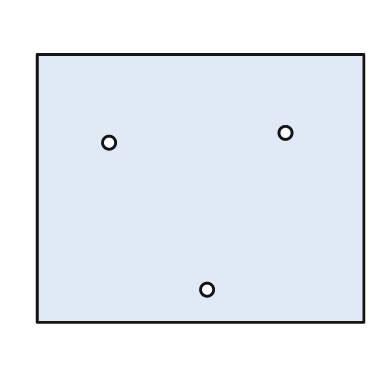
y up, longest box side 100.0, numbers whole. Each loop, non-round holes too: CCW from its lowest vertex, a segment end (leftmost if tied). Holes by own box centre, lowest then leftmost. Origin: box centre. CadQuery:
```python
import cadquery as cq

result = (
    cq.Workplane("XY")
    .moveTo(-50.0, -41.0)
    .lineTo(50.0, -41.0)
    .lineTo(50.0, 41.0)
    .lineTo(-50.0, 41.0)
    .close()
    .moveTo(2.0, -31.0)
    .circle(2.0)
    .moveTo(-28.0, 14.0)
    .circle(2.0)
    .moveTo(26.0, 17.0)
    .circle(2.0)
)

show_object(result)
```